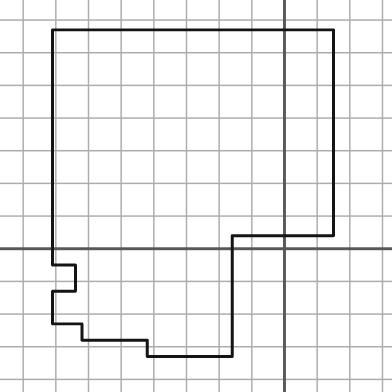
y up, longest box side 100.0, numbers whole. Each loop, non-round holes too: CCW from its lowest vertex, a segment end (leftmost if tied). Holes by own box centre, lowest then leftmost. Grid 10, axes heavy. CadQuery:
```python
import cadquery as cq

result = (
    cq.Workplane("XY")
    .moveTo(-42.0, -33.0)
    .lineTo(-16.0, -33.0)
    .lineTo(-16.0, 4.0)
    .lineTo(15.0, 4.0)
    .lineTo(15.0, 67.0)
    .lineTo(-71.0, 67.0)
    .lineTo(-71.0, -5.0)
    .lineTo(-64.0, -5.0)
    .lineTo(-64.0, -13.0)
    .lineTo(-71.0, -13.0)
    .lineTo(-71.0, -23.0)
    .lineTo(-62.0, -23.0)
    .lineTo(-62.0, -28.0)
    .lineTo(-42.0, -28.0)
    .close()
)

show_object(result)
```